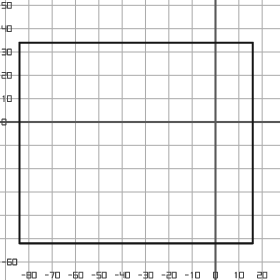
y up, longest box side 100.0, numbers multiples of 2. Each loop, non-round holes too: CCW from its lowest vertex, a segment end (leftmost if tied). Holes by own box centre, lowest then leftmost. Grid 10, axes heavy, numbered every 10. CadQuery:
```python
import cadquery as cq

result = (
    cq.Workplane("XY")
    .moveTo(-84.0, -52.0)
    .lineTo(16.0, -52.0)
    .lineTo(16.0, 34.0)
    .lineTo(-84.0, 34.0)
    .close()
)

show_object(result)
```